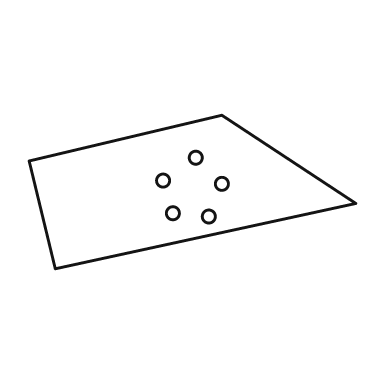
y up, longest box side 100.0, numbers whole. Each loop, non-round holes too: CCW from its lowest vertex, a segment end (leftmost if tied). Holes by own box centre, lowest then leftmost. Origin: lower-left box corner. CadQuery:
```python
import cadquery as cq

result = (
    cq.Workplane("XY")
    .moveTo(8.0, 0.0)
    .lineTo(100.0, 20.0)
    .lineTo(59.0, 47.0)
    .lineTo(0.0, 33.0)
    .close()
    .moveTo(55.0, 16.0)
    .circle(2.0)
    .moveTo(44.0, 17.0)
    .circle(2.0)
    .moveTo(59.0, 26.0)
    .circle(2.0)
    .moveTo(41.0, 27.0)
    .circle(2.0)
    .moveTo(51.0, 34.0)
    .circle(2.0)
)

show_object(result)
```